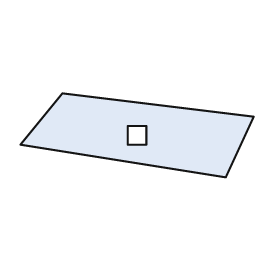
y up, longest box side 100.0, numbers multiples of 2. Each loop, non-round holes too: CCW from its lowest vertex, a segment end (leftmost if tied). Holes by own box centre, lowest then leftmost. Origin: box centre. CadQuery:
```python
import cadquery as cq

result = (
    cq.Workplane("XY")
    .moveTo(38.0, -18.0)
    .lineTo(50.0, 8.0)
    .lineTo(-32.0, 18.0)
    .lineTo(-50.0, -4.0)
    .close()
    .moveTo(-4.0, -4.0)
    .lineTo(4.0, -4.0)
    .lineTo(4.0, 4.0)
    .lineTo(-4.0, 4.0)
    .close()
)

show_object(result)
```